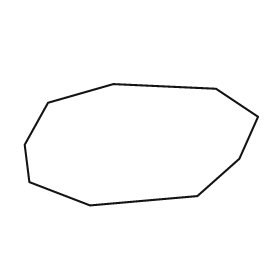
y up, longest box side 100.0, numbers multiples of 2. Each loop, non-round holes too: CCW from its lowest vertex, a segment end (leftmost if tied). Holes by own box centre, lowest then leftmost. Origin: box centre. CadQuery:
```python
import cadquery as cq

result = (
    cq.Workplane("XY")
    .moveTo(-22.0, -26.0)
    .lineTo(24.0, -22.0)
    .lineTo(42.0, -6.0)
    .lineTo(50.0, 12.0)
    .lineTo(32.0, 24.0)
    .lineTo(-12.0, 26.0)
    .lineTo(-40.0, 18.0)
    .lineTo(-50.0, 0.0)
    .lineTo(-48.0, -16.0)
    .close()
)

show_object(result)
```